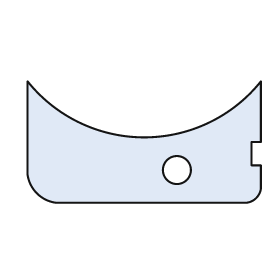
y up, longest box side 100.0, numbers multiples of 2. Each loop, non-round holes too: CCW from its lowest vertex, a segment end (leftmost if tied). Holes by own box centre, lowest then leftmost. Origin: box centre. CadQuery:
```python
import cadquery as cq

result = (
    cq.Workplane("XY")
    .moveTo(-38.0, -26.0)
    .lineTo(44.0, -26.0)
    .threePointArc((48.0, -24.0), (50.0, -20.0))
    .lineTo(50.0, -10.0)
    .lineTo(46.0, -10.0)
    .lineTo(46.0, 0.0)
    .lineTo(50.0, 0.0)
    .lineTo(50.0, 26.0)
    .threePointArc((0.0, 2.0), (-50.0, 26.0))
    .lineTo(-50.0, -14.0)
    .threePointArc((-46.0, -22.0), (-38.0, -26.0))
    .close()
    .moveTo(14.0, -12.0)
    .circle(6.0)
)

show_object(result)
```